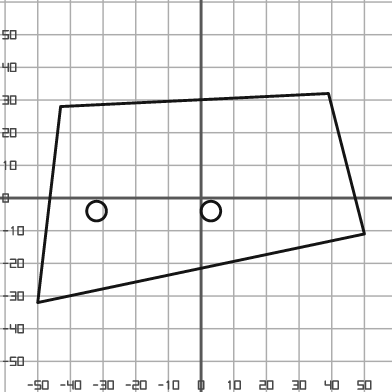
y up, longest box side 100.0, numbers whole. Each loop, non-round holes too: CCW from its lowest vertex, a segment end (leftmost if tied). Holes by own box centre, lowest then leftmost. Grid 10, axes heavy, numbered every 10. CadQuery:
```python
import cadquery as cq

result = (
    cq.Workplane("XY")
    .moveTo(-50.0, -32.0)
    .lineTo(50.0, -11.0)
    .lineTo(39.0, 32.0)
    .lineTo(-43.0, 28.0)
    .close()
    .moveTo(-32.0, -4.0)
    .circle(3.0)
    .moveTo(3.0, -4.0)
    .circle(3.0)
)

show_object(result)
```